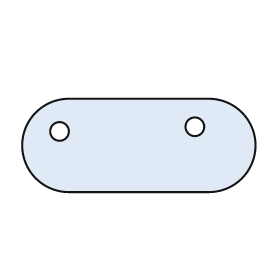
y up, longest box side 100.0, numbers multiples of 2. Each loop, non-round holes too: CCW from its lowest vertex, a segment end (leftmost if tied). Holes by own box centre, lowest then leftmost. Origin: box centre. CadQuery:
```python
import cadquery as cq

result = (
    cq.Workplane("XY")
    .moveTo(-30.0, -20.0)
    .lineTo(30.0, -20.0)
    .threePointArc((50.0, 0.0), (30.0, 20.0))
    .lineTo(-30.0, 20.0)
    .threePointArc((-50.0, 0.0), (-30.0, -20.0))
    .close()
    .moveTo(-34.0, 6.0)
    .circle(4.0)
    .moveTo(24.0, 8.0)
    .circle(4.0)
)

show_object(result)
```